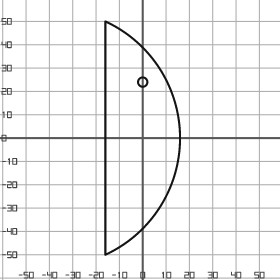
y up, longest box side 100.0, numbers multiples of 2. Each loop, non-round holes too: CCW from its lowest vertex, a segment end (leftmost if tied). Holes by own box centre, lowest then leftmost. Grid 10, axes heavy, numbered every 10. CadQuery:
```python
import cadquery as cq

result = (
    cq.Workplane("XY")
    .moveTo(-16.0, -50.0)
    .threePointArc((16.0, 0.0), (-16.0, 50.0))
    .close()
    .moveTo(0.0, 24.0)
    .circle(2.0)
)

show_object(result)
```